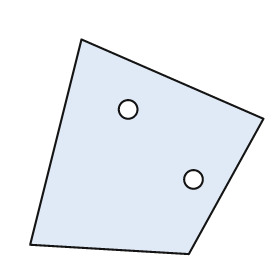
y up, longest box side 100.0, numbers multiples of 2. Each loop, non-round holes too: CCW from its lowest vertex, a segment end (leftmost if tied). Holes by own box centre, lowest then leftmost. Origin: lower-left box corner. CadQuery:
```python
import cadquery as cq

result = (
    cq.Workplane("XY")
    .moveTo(68.0, 0.0)
    .lineTo(100.0, 58.0)
    .lineTo(22.0, 92.0)
    .lineTo(0.0, 4.0)
    .close()
    .moveTo(70.0, 32.0)
    .circle(4.0)
    .moveTo(42.0, 62.0)
    .circle(4.0)
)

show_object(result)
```